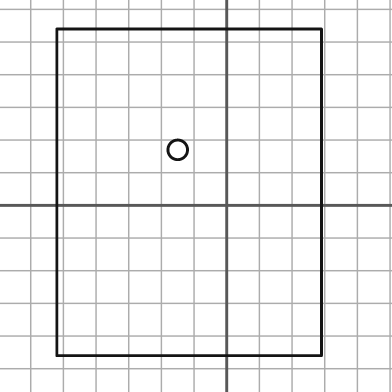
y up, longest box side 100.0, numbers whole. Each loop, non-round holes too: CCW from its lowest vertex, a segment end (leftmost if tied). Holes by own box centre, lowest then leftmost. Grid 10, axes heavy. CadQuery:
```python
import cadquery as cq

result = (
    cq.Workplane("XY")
    .moveTo(-52.0, -46.0)
    .lineTo(29.0, -46.0)
    .lineTo(29.0, 54.0)
    .lineTo(-52.0, 54.0)
    .close()
    .moveTo(-15.0, 17.0)
    .circle(3.0)
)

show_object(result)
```